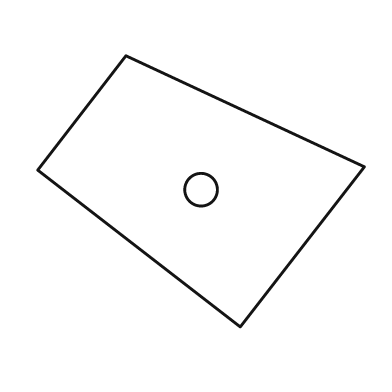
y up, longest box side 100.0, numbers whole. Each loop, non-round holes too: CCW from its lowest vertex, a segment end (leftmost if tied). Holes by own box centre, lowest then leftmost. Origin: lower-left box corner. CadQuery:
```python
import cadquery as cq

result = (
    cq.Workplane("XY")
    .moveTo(62.0, 0.0)
    .lineTo(100.0, 49.0)
    .lineTo(27.0, 83.0)
    .lineTo(0.0, 48.0)
    .close()
    .moveTo(50.0, 42.0)
    .circle(5.0)
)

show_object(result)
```